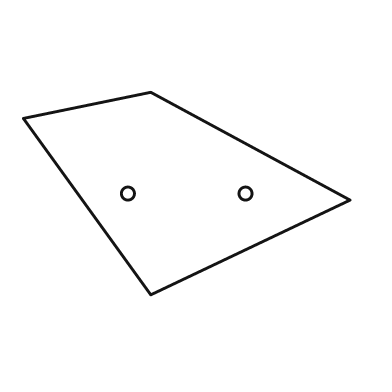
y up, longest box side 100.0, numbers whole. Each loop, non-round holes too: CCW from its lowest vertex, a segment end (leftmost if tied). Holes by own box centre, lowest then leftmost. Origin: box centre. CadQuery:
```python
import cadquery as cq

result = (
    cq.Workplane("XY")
    .moveTo(-11.0, -31.0)
    .lineTo(50.0, -2.0)
    .lineTo(-11.0, 31.0)
    .lineTo(-50.0, 23.0)
    .close()
    .moveTo(-18.0, 0.0)
    .circle(2.0)
    .moveTo(18.0, 0.0)
    .circle(2.0)
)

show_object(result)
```